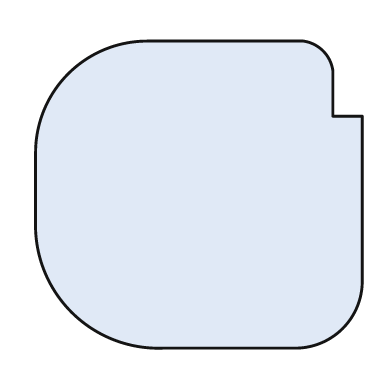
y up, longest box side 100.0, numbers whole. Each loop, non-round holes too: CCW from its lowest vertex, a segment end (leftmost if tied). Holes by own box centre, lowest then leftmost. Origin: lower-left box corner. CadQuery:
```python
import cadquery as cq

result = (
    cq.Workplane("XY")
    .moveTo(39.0, 0.0)
    .lineTo(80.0, 0.0)
    .threePointArc((94.0, 6.0), (100.0, 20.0))
    .lineTo(100.0, 71.0)
    .lineTo(91.0, 71.0)
    .lineTo(91.0, 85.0)
    .threePointArc((88.0, 91.0), (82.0, 94.0))
    .lineTo(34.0, 94.0)
    .threePointArc((10.0, 84.0), (0.0, 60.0))
    .lineTo(0.0, 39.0)
    .threePointArc((11.0, 11.0), (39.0, 0.0))
    .close()
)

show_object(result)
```